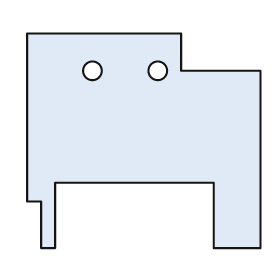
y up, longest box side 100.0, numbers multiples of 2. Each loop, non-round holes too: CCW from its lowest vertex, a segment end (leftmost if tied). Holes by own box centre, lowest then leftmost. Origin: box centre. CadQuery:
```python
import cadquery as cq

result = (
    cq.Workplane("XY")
    .moveTo(-44.0, -46.0)
    .lineTo(-38.0, -46.0)
    .lineTo(-38.0, -18.0)
    .lineTo(30.0, -18.0)
    .lineTo(30.0, -46.0)
    .lineTo(50.0, -46.0)
    .lineTo(50.0, 30.0)
    .lineTo(16.0, 30.0)
    .lineTo(16.0, 46.0)
    .lineTo(-50.0, 46.0)
    .lineTo(-50.0, -26.0)
    .lineTo(-44.0, -26.0)
    .close()
    .moveTo(-22.0, 30.0)
    .circle(4.0)
    .moveTo(6.0, 30.0)
    .circle(4.0)
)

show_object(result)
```